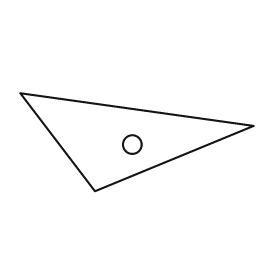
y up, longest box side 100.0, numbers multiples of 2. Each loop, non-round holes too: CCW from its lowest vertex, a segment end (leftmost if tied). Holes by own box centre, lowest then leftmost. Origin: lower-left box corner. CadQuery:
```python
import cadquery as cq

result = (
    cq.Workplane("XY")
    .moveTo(32.0, 0.0)
    .lineTo(100.0, 28.0)
    .lineTo(0.0, 42.0)
    .close()
    .moveTo(48.0, 20.0)
    .circle(4.0)
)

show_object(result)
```